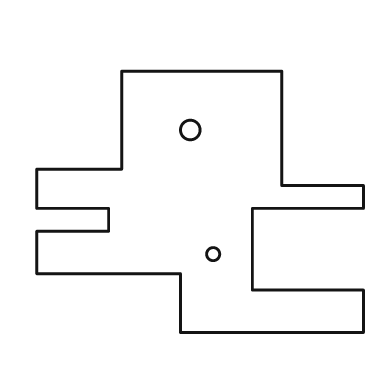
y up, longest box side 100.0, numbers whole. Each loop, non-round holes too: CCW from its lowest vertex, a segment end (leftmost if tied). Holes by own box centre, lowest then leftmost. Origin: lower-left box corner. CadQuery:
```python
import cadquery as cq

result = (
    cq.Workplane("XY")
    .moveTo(44.0, 0.0)
    .lineTo(100.0, 0.0)
    .lineTo(100.0, 13.0)
    .lineTo(66.0, 13.0)
    .lineTo(66.0, 38.0)
    .lineTo(100.0, 38.0)
    .lineTo(100.0, 45.0)
    .lineTo(75.0, 45.0)
    .lineTo(75.0, 80.0)
    .lineTo(26.0, 80.0)
    .lineTo(26.0, 50.0)
    .lineTo(0.0, 50.0)
    .lineTo(0.0, 38.0)
    .lineTo(22.0, 38.0)
    .lineTo(22.0, 31.0)
    .lineTo(0.0, 31.0)
    .lineTo(0.0, 18.0)
    .lineTo(44.0, 18.0)
    .close()
    .moveTo(54.0, 24.0)
    .circle(2.0)
    .moveTo(47.0, 62.0)
    .circle(3.0)
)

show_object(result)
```